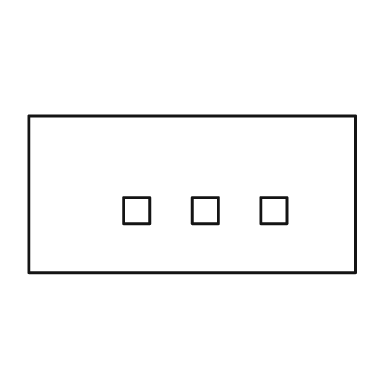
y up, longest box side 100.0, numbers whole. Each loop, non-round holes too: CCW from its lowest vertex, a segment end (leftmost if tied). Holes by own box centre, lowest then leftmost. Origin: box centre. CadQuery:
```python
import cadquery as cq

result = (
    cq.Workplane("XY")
    .moveTo(-50.0, -24.0)
    .lineTo(50.0, -24.0)
    .lineTo(50.0, 24.0)
    .lineTo(-50.0, 24.0)
    .close()
    .moveTo(-21.0, -9.0)
    .lineTo(-13.0, -9.0)
    .lineTo(-13.0, -1.0)
    .lineTo(-21.0, -1.0)
    .close()
    .moveTo(0.0, -9.0)
    .lineTo(8.0, -9.0)
    .lineTo(8.0, -1.0)
    .lineTo(0.0, -1.0)
    .close()
    .moveTo(21.0, -9.0)
    .lineTo(29.0, -9.0)
    .lineTo(29.0, -1.0)
    .lineTo(21.0, -1.0)
    .close()
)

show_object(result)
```